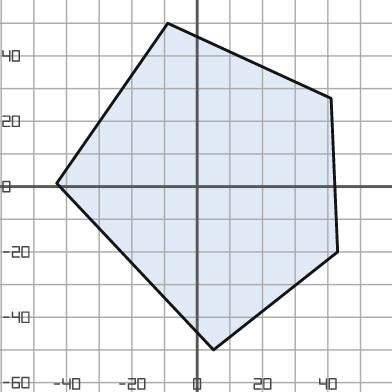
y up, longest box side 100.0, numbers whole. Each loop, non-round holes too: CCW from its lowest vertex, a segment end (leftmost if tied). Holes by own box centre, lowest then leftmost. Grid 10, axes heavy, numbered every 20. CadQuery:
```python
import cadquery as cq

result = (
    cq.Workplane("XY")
    .moveTo(5.0, -50.0)
    .lineTo(43.0, -20.0)
    .lineTo(41.0, 27.0)
    .lineTo(-9.0, 50.0)
    .lineTo(-43.0, 1.0)
    .close()
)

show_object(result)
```